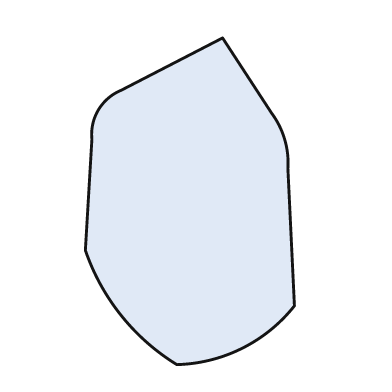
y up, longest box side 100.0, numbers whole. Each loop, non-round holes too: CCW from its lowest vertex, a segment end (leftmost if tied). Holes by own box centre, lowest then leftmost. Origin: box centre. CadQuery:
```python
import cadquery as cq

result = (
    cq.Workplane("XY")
    .moveTo(-4.0, -50.0)
    .threePointArc((16.0, -45.0), (32.0, -32.0))
    .lineTo(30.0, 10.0)
    .threePointArc((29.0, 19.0), (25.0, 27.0))
    .lineTo(10.0, 50.0)
    .lineTo(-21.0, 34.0)
    .threePointArc((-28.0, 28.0), (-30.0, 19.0))
    .lineTo(-32.0, -15.0)
    .threePointArc((-21.0, -35.0), (-4.0, -50.0))
    .close()
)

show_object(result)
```